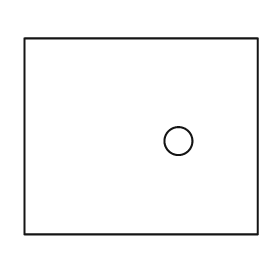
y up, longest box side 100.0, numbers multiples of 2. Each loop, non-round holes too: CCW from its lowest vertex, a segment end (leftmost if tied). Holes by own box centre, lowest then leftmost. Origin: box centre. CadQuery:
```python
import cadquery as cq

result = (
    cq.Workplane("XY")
    .moveTo(-50.0, -42.0)
    .lineTo(50.0, -42.0)
    .lineTo(50.0, 42.0)
    .lineTo(-50.0, 42.0)
    .close()
    .moveTo(16.0, -2.0)
    .circle(6.0)
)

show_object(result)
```